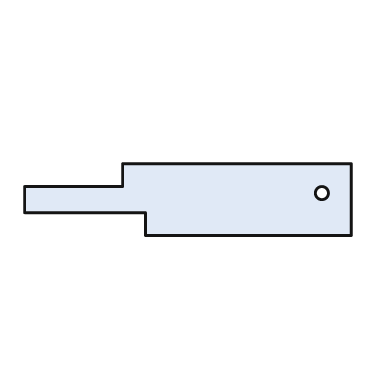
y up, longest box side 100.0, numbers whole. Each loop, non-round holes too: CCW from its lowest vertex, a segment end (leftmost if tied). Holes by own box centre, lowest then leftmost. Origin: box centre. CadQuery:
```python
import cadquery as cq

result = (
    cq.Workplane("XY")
    .moveTo(-13.0, -11.0)
    .lineTo(50.0, -11.0)
    .lineTo(50.0, 11.0)
    .lineTo(-20.0, 11.0)
    .lineTo(-20.0, 4.0)
    .lineTo(-50.0, 4.0)
    .lineTo(-50.0, -4.0)
    .lineTo(-13.0, -4.0)
    .close()
    .moveTo(41.0, 2.0)
    .circle(2.0)
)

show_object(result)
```